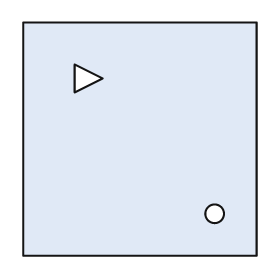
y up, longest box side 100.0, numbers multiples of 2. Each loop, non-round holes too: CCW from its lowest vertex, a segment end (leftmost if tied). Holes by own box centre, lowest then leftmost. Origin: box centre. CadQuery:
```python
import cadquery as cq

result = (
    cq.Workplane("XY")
    .moveTo(-50.0, -50.0)
    .lineTo(50.0, -50.0)
    .lineTo(50.0, 50.0)
    .lineTo(-50.0, 50.0)
    .close()
    .moveTo(32.0, -32.0)
    .circle(4.0)
    .moveTo(-28.0, 20.0)
    .lineTo(-16.0, 26.0)
    .lineTo(-28.0, 32.0)
    .close()
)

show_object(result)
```